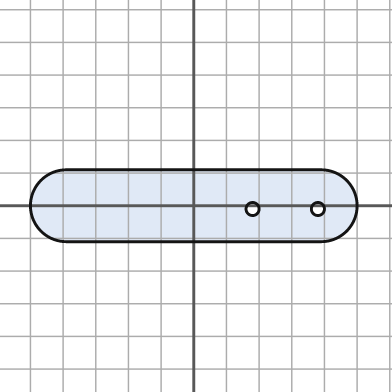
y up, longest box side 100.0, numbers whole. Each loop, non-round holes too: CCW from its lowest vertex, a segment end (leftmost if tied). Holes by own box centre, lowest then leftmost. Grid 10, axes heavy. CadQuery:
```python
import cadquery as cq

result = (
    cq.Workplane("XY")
    .moveTo(-39.0, -11.0)
    .lineTo(39.0, -11.0)
    .threePointArc((50.0, 0.0), (39.0, 11.0))
    .lineTo(-39.0, 11.0)
    .threePointArc((-50.0, 0.0), (-39.0, -11.0))
    .close()
    .moveTo(18.0, -1.0)
    .circle(2.0)
    .moveTo(38.0, -1.0)
    .circle(2.0)
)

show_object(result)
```